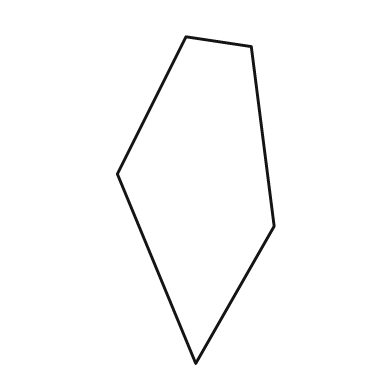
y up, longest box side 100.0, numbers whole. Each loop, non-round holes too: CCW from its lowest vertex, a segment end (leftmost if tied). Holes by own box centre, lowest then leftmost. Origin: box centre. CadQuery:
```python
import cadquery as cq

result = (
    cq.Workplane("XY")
    .moveTo(0.0, -50.0)
    .lineTo(24.0, -8.0)
    .lineTo(17.0, 47.0)
    .lineTo(-3.0, 50.0)
    .lineTo(-24.0, 8.0)
    .close()
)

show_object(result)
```